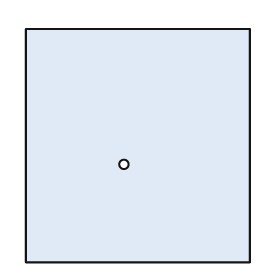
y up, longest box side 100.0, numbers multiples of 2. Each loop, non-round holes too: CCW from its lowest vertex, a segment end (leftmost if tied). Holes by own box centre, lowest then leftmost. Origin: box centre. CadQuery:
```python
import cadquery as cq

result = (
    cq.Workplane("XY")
    .moveTo(-48.0, -50.0)
    .lineTo(48.0, -50.0)
    .lineTo(48.0, 50.0)
    .lineTo(-48.0, 50.0)
    .close()
    .moveTo(-6.0, -8.0)
    .circle(2.0)
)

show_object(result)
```